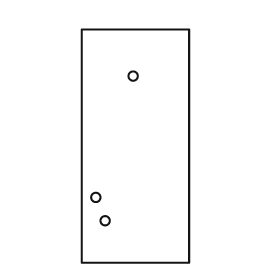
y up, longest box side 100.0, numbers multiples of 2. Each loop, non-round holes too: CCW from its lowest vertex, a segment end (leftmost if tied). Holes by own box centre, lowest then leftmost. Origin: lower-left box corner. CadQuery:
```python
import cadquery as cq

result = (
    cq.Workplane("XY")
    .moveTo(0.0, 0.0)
    .lineTo(46.0, 0.0)
    .lineTo(46.0, 100.0)
    .lineTo(0.0, 100.0)
    .close()
    .moveTo(10.0, 18.0)
    .circle(2.0)
    .moveTo(6.0, 28.0)
    .circle(2.0)
    .moveTo(22.0, 80.0)
    .circle(2.0)
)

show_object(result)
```